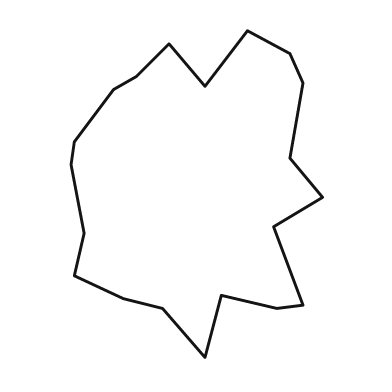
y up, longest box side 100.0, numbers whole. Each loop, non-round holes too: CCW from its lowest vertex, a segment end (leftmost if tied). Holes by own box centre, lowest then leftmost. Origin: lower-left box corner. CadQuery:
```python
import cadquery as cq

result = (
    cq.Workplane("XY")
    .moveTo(41.0, 0.0)
    .lineTo(46.0, 19.0)
    .lineTo(63.0, 15.0)
    .lineTo(71.0, 16.0)
    .lineTo(62.0, 40.0)
    .lineTo(77.0, 49.0)
    .lineTo(67.0, 61.0)
    .lineTo(71.0, 84.0)
    .lineTo(67.0, 93.0)
    .lineTo(54.0, 100.0)
    .lineTo(41.0, 83.0)
    .lineTo(30.0, 96.0)
    .lineTo(20.0, 86.0)
    .lineTo(13.0, 82.0)
    .lineTo(1.0, 66.0)
    .lineTo(0.0, 59.0)
    .lineTo(4.0, 38.0)
    .lineTo(1.0, 25.0)
    .lineTo(16.0, 18.0)
    .lineTo(28.0, 15.0)
    .close()
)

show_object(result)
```